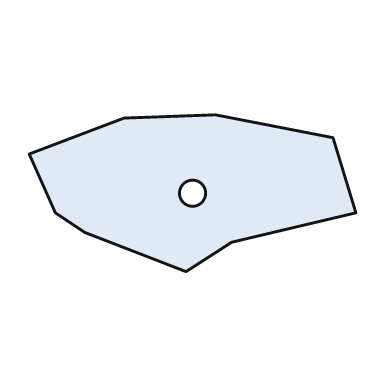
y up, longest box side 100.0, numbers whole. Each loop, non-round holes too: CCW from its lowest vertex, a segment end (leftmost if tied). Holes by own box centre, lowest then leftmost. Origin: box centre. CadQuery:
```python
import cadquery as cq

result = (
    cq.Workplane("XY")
    .moveTo(-2.0, -24.0)
    .lineTo(12.0, -15.0)
    .lineTo(50.0, -6.0)
    .lineTo(43.0, 17.0)
    .lineTo(7.0, 24.0)
    .lineTo(-21.0, 23.0)
    .lineTo(-50.0, 12.0)
    .lineTo(-42.0, -6.0)
    .lineTo(-33.0, -12.0)
    .close()
    .moveTo(0.0, 0.0)
    .circle(4.0)
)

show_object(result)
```